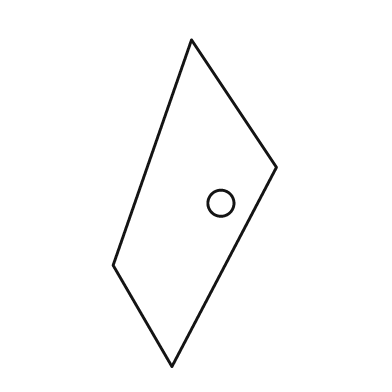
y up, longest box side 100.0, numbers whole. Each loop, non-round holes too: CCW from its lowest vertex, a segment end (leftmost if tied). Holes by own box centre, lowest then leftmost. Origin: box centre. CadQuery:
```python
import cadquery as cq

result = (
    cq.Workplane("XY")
    .moveTo(-7.0, -50.0)
    .lineTo(25.0, 11.0)
    .lineTo(-1.0, 50.0)
    .lineTo(-25.0, -19.0)
    .close()
    .moveTo(8.0, 0.0)
    .circle(4.0)
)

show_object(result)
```